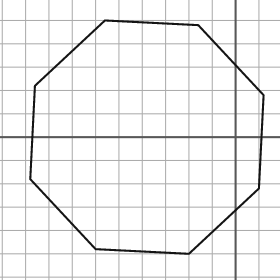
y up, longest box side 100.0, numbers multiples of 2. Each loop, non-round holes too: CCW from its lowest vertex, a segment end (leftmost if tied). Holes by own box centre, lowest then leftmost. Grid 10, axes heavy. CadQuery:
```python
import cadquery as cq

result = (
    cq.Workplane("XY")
    .moveTo(-20.0, -50.0)
    .lineTo(10.0, -22.0)
    .lineTo(12.0, 18.0)
    .lineTo(-16.0, 48.0)
    .lineTo(-56.0, 50.0)
    .lineTo(-86.0, 22.0)
    .lineTo(-88.0, -18.0)
    .lineTo(-60.0, -48.0)
    .close()
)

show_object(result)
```